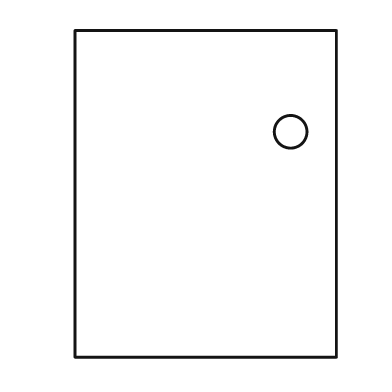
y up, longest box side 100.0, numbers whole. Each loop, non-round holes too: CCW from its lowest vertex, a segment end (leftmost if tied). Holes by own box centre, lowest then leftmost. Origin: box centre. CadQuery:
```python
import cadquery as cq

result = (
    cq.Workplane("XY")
    .moveTo(-40.0, -50.0)
    .lineTo(40.0, -50.0)
    .lineTo(40.0, 50.0)
    .lineTo(-40.0, 50.0)
    .close()
    .moveTo(26.0, 19.0)
    .circle(5.0)
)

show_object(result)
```